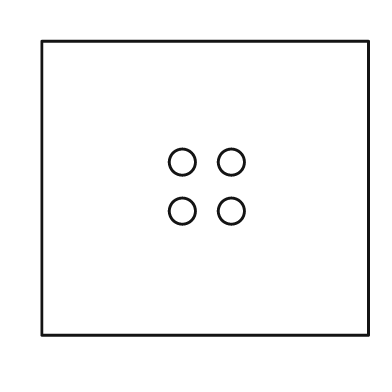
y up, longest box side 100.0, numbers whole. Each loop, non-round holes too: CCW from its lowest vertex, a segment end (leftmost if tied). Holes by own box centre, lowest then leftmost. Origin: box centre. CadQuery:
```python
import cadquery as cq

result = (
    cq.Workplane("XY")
    .moveTo(-50.0, -45.0)
    .lineTo(50.0, -45.0)
    .lineTo(50.0, 45.0)
    .lineTo(-50.0, 45.0)
    .close()
    .moveTo(-7.0, -7.0)
    .circle(4.0)
    .moveTo(8.0, -7.0)
    .circle(4.0)
    .moveTo(-7.0, 8.0)
    .circle(4.0)
    .moveTo(8.0, 8.0)
    .circle(4.0)
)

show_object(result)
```